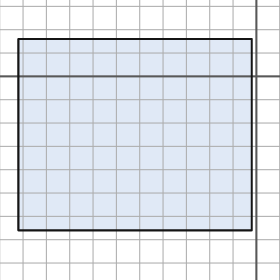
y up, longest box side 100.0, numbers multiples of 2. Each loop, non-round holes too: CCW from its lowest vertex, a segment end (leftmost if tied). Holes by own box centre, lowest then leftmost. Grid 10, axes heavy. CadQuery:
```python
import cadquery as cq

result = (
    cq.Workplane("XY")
    .moveTo(-102.0, -66.0)
    .lineTo(-2.0, -66.0)
    .lineTo(-2.0, 16.0)
    .lineTo(-102.0, 16.0)
    .close()
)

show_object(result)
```